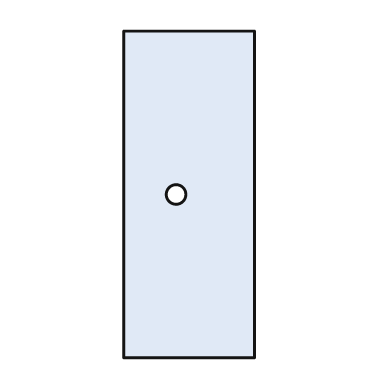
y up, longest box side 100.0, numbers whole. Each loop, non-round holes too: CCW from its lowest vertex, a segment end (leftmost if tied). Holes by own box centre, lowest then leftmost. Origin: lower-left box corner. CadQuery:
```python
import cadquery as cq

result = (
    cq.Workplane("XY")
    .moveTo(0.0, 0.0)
    .lineTo(40.0, 0.0)
    .lineTo(40.0, 100.0)
    .lineTo(0.0, 100.0)
    .close()
    .moveTo(16.0, 50.0)
    .circle(3.0)
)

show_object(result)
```